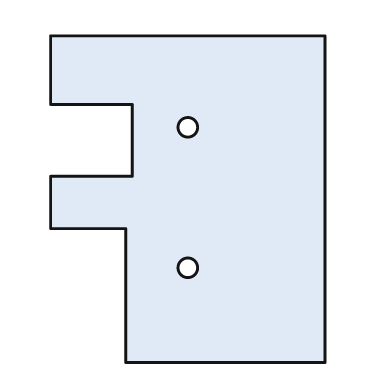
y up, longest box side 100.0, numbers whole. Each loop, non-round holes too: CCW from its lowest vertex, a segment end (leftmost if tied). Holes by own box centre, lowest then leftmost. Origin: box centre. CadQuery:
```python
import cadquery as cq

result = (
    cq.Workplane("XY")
    .moveTo(-19.0, -50.0)
    .lineTo(42.0, -50.0)
    .lineTo(42.0, 50.0)
    .lineTo(-42.0, 50.0)
    .lineTo(-42.0, 29.0)
    .lineTo(-17.0, 29.0)
    .lineTo(-17.0, 7.0)
    .lineTo(-42.0, 7.0)
    .lineTo(-42.0, -9.0)
    .lineTo(-19.0, -9.0)
    .close()
    .moveTo(0.0, -21.0)
    .circle(3.0)
    .moveTo(0.0, 22.0)
    .circle(3.0)
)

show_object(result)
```